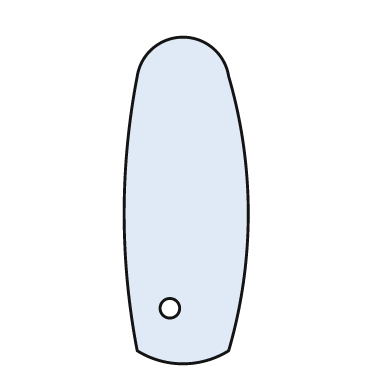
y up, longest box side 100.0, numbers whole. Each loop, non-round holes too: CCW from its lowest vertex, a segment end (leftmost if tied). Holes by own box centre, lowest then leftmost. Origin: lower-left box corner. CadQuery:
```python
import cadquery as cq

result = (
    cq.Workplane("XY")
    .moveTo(4.0, 4.0)
    .threePointArc((18.0, 0.0), (32.0, 4.0))
    .threePointArc((38.0, 46.0), (32.0, 88.0))
    .threePointArc((18.0, 100.0), (4.0, 88.0))
    .threePointArc((0.0, 46.0), (4.0, 4.0))
    .close()
    .moveTo(14.0, 17.0)
    .circle(3.0)
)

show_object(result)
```